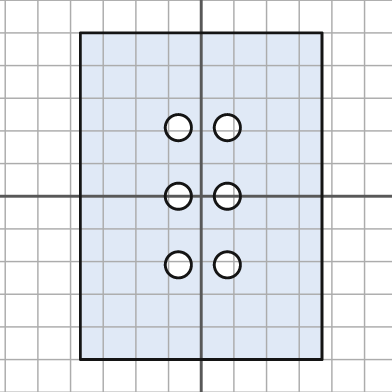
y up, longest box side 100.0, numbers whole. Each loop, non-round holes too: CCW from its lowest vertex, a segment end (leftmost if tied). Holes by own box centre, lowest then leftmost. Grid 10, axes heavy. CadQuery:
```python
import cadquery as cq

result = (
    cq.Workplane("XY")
    .moveTo(-37.0, -50.0)
    .lineTo(37.0, -50.0)
    .lineTo(37.0, 50.0)
    .lineTo(-37.0, 50.0)
    .close()
    .moveTo(-7.0, -21.0)
    .circle(4.0)
    .moveTo(8.0, -21.0)
    .circle(4.0)
    .moveTo(-7.0, 0.0)
    .circle(4.0)
    .moveTo(8.0, 0.0)
    .circle(4.0)
    .moveTo(-7.0, 21.0)
    .circle(4.0)
    .moveTo(8.0, 21.0)
    .circle(4.0)
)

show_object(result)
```